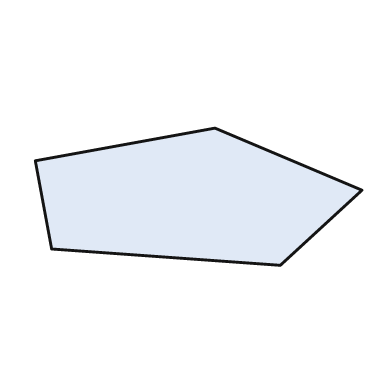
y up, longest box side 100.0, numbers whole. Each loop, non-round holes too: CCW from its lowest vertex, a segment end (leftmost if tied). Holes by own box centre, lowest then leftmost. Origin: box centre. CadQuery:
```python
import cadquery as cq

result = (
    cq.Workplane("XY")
    .moveTo(25.0, -21.0)
    .lineTo(50.0, 2.0)
    .lineTo(5.0, 21.0)
    .lineTo(-50.0, 11.0)
    .lineTo(-45.0, -16.0)
    .close()
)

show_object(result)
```